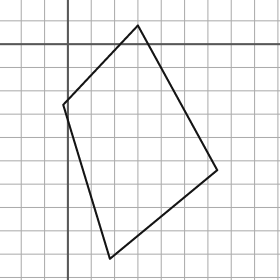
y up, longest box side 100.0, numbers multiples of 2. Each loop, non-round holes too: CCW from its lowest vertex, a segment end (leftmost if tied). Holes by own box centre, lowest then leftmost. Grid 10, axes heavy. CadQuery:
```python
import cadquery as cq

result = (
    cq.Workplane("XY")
    .moveTo(18.0, -92.0)
    .lineTo(64.0, -54.0)
    .lineTo(30.0, 8.0)
    .lineTo(-2.0, -26.0)
    .close()
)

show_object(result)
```